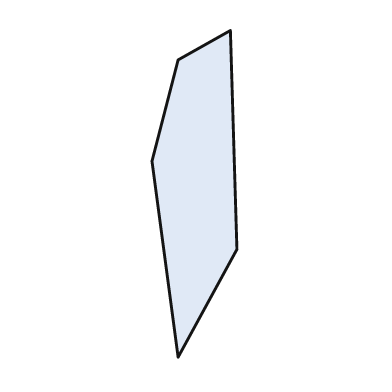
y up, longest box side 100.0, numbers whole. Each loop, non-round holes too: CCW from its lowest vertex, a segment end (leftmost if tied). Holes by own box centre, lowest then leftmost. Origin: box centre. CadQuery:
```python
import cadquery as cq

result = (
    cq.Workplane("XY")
    .moveTo(-5.0, -50.0)
    .lineTo(13.0, -17.0)
    .lineTo(11.0, 50.0)
    .lineTo(-5.0, 41.0)
    .lineTo(-13.0, 10.0)
    .close()
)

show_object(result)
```